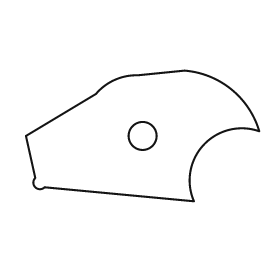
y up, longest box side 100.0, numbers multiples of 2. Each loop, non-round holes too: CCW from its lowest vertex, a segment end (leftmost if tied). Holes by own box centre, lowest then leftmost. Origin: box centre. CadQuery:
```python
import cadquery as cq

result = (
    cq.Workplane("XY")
    .moveTo(22.0, -28.0)
    .threePointArc((26.0, -4.0), (50.0, 2.0))
    .threePointArc((38.0, 20.0), (18.0, 28.0))
    .lineTo(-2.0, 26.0)
    .threePointArc((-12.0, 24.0), (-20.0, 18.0))
    .lineTo(-50.0, 0.0)
    .lineTo(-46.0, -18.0)
    .threePointArc((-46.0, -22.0), (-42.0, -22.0))
    .close()
    .moveTo(0.0, 0.0)
    .circle(6.0)
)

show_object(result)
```